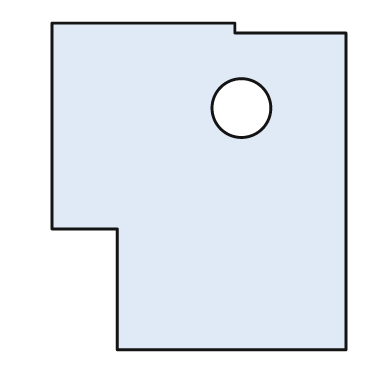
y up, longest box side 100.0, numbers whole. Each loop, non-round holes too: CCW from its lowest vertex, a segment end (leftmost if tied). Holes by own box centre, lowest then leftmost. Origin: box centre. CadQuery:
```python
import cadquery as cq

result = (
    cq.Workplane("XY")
    .moveTo(-25.0, -50.0)
    .lineTo(45.0, -50.0)
    .lineTo(45.0, 47.0)
    .lineTo(11.0, 47.0)
    .lineTo(11.0, 50.0)
    .lineTo(-45.0, 50.0)
    .lineTo(-45.0, -13.0)
    .lineTo(-25.0, -13.0)
    .close()
    .moveTo(13.0, 24.0)
    .circle(9.0)
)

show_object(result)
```